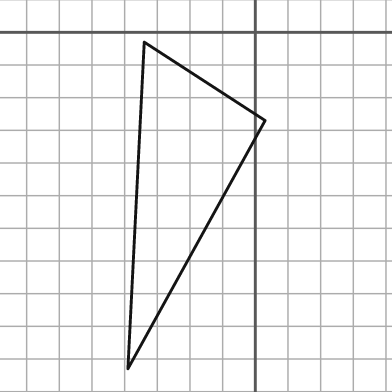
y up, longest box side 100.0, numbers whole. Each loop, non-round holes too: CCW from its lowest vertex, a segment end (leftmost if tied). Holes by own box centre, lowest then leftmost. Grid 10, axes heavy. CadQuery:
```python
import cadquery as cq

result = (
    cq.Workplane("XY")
    .moveTo(-39.0, -103.0)
    .lineTo(3.0, -27.0)
    .lineTo(-34.0, -3.0)
    .close()
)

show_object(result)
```